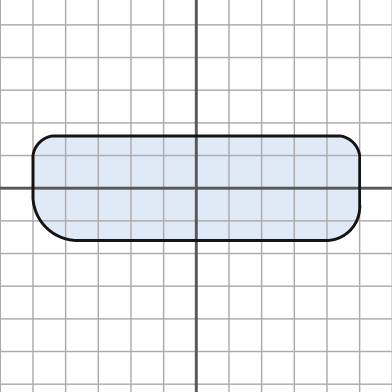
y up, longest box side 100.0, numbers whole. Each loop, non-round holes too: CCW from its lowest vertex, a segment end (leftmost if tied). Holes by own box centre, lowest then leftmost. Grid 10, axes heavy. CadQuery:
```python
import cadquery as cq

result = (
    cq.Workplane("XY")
    .moveTo(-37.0, -16.0)
    .lineTo(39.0, -16.0)
    .threePointArc((47.0, -13.0), (50.0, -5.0))
    .lineTo(50.0, 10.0)
    .threePointArc((48.0, 14.0), (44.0, 16.0))
    .lineTo(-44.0, 16.0)
    .threePointArc((-48.0, 14.0), (-50.0, 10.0))
    .lineTo(-50.0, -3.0)
    .threePointArc((-46.0, -12.0), (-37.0, -16.0))
    .close()
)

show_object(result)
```